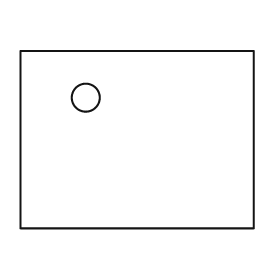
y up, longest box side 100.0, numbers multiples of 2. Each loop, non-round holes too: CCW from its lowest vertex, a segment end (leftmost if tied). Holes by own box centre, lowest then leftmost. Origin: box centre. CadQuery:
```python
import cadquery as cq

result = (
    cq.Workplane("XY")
    .moveTo(-50.0, -38.0)
    .lineTo(50.0, -38.0)
    .lineTo(50.0, 38.0)
    .lineTo(-50.0, 38.0)
    .close()
    .moveTo(-22.0, 18.0)
    .circle(6.0)
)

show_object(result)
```